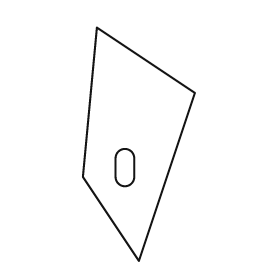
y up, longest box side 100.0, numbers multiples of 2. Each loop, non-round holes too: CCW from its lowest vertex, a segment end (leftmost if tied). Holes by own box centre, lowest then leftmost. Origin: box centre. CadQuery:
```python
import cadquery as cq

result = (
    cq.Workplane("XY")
    .moveTo(0.0, -50.0)
    .lineTo(24.0, 22.0)
    .lineTo(-18.0, 50.0)
    .lineTo(-24.0, -14.0)
    .close()
    .moveTo(-10.0, -14.0)
    .threePointArc((-6.0, -18.0), (-2.0, -14.0))
    .lineTo(-2.0, -6.0)
    .threePointArc((-6.0, -2.0), (-10.0, -6.0))
    .close()
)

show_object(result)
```